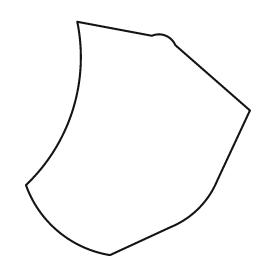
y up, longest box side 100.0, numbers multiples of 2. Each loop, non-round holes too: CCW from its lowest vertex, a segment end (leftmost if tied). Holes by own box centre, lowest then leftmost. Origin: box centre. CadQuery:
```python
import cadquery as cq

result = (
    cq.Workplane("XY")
    .moveTo(-12.0, -50.0)
    .lineTo(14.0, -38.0)
    .threePointArc((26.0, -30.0), (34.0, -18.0))
    .lineTo(48.0, 12.0)
    .lineTo(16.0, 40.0)
    .threePointArc((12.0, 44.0), (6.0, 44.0))
    .lineTo(-26.0, 50.0)
    .threePointArc((-28.0, 12.0), (-48.0, -20.0))
    .threePointArc((-34.0, -40.0), (-12.0, -50.0))
    .close()
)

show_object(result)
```